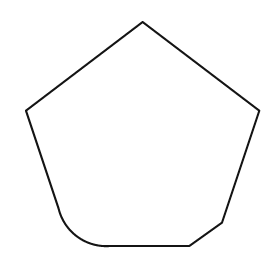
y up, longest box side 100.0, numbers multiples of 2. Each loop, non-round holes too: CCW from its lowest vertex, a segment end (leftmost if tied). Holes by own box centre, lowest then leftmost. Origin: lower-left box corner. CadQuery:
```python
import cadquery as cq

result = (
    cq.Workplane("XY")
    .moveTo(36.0, 0.0)
    .lineTo(70.0, 0.0)
    .lineTo(84.0, 10.0)
    .lineTo(100.0, 58.0)
    .lineTo(50.0, 96.0)
    .lineTo(0.0, 58.0)
    .lineTo(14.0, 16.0)
    .threePointArc((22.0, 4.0), (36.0, 0.0))
    .close()
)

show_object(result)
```